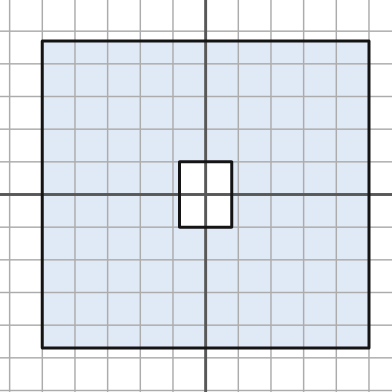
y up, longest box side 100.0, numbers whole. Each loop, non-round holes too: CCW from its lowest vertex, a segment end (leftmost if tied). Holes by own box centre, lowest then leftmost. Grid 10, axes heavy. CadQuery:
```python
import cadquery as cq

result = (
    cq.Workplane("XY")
    .moveTo(-50.0, -47.0)
    .lineTo(50.0, -47.0)
    .lineTo(50.0, 47.0)
    .lineTo(-50.0, 47.0)
    .close()
    .moveTo(-8.0, -10.0)
    .lineTo(8.0, -10.0)
    .lineTo(8.0, 10.0)
    .lineTo(-8.0, 10.0)
    .close()
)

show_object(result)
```